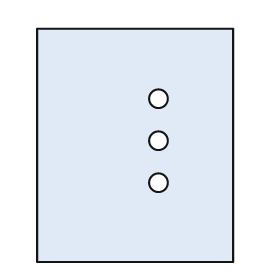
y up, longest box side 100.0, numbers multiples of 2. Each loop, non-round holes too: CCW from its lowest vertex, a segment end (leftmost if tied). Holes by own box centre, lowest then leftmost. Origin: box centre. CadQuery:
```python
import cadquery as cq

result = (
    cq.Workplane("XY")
    .moveTo(-42.0, -50.0)
    .lineTo(42.0, -50.0)
    .lineTo(42.0, 50.0)
    .lineTo(-42.0, 50.0)
    .close()
    .moveTo(10.0, -16.0)
    .circle(4.0)
    .moveTo(10.0, 2.0)
    .circle(4.0)
    .moveTo(10.0, 20.0)
    .circle(4.0)
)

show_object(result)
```